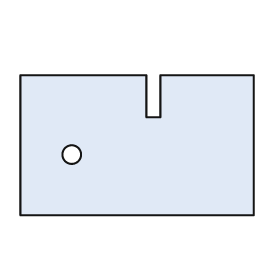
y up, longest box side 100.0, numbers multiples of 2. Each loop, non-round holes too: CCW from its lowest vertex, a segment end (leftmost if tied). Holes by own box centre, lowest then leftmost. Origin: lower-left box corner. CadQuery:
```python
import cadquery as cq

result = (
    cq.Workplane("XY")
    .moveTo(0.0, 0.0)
    .lineTo(100.0, 0.0)
    .lineTo(100.0, 60.0)
    .lineTo(60.0, 60.0)
    .lineTo(60.0, 42.0)
    .lineTo(54.0, 42.0)
    .lineTo(54.0, 60.0)
    .lineTo(0.0, 60.0)
    .close()
    .moveTo(22.0, 26.0)
    .circle(4.0)
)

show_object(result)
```